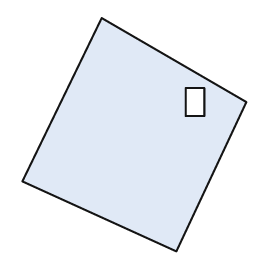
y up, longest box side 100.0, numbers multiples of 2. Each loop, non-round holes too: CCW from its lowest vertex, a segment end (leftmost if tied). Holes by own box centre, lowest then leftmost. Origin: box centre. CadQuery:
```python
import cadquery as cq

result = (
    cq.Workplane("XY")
    .moveTo(18.0, -50.0)
    .lineTo(48.0, 14.0)
    .lineTo(-14.0, 50.0)
    .lineTo(-48.0, -20.0)
    .close()
    .moveTo(22.0, 8.0)
    .lineTo(30.0, 8.0)
    .lineTo(30.0, 20.0)
    .lineTo(22.0, 20.0)
    .close()
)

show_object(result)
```